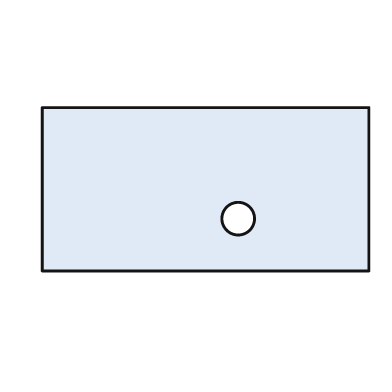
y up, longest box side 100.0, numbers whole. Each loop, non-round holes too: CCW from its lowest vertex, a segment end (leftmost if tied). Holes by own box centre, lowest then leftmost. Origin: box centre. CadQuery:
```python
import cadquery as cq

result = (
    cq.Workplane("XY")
    .moveTo(-50.0, -25.0)
    .lineTo(50.0, -25.0)
    .lineTo(50.0, 25.0)
    .lineTo(-50.0, 25.0)
    .close()
    .moveTo(10.0, -9.0)
    .circle(5.0)
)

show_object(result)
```